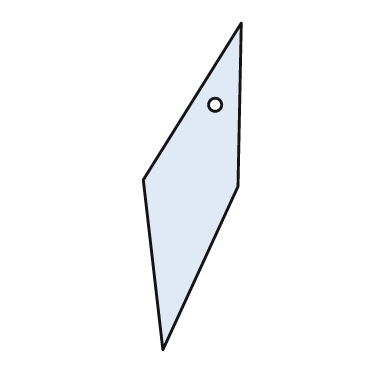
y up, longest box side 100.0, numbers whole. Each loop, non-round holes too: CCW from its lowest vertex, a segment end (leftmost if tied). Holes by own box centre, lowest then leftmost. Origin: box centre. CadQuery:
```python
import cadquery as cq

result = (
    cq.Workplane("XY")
    .moveTo(-9.0, -50.0)
    .lineTo(14.0, 0.0)
    .lineTo(15.0, 50.0)
    .lineTo(-15.0, 2.0)
    .close()
    .moveTo(7.0, 25.0)
    .circle(2.0)
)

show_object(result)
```